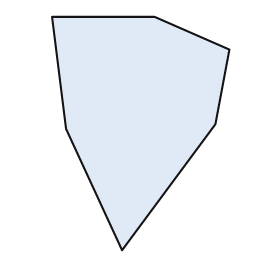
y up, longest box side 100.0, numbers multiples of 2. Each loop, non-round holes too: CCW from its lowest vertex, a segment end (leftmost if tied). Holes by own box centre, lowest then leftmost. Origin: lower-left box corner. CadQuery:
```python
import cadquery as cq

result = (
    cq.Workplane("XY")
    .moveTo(30.0, 0.0)
    .lineTo(70.0, 54.0)
    .lineTo(76.0, 86.0)
    .lineTo(44.0, 100.0)
    .lineTo(0.0, 100.0)
    .lineTo(6.0, 52.0)
    .close()
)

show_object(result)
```